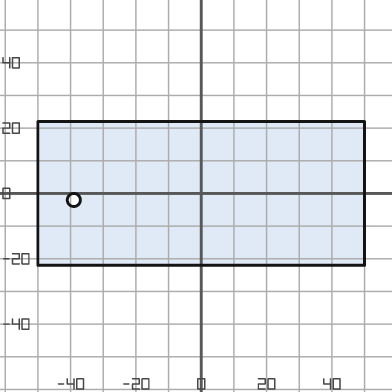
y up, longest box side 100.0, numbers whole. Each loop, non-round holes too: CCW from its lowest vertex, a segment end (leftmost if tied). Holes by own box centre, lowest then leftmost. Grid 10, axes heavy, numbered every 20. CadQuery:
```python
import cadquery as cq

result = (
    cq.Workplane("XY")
    .moveTo(-50.0, -22.0)
    .lineTo(50.0, -22.0)
    .lineTo(50.0, 22.0)
    .lineTo(-50.0, 22.0)
    .close()
    .moveTo(-39.0, -2.0)
    .circle(2.0)
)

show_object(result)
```